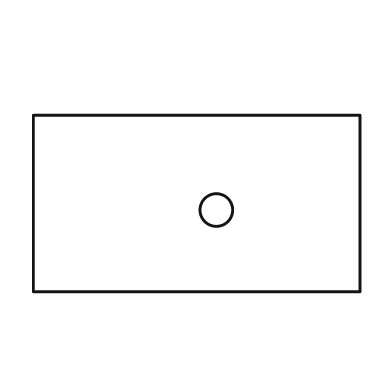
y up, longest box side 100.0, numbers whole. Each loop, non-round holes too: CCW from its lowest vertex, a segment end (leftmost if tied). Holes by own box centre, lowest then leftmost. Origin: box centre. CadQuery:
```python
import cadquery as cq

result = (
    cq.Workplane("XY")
    .moveTo(-50.0, -27.0)
    .lineTo(50.0, -27.0)
    .lineTo(50.0, 27.0)
    .lineTo(-50.0, 27.0)
    .close()
    .moveTo(6.0, -2.0)
    .circle(5.0)
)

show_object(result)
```